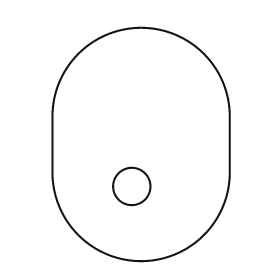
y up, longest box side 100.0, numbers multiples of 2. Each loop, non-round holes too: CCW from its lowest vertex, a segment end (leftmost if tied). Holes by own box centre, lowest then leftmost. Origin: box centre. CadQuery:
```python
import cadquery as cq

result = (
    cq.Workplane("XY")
    .moveTo(-38.0, -12.0)
    .threePointArc((0.0, -50.0), (38.0, -12.0))
    .lineTo(38.0, 12.0)
    .threePointArc((0.0, 50.0), (-38.0, 12.0))
    .close()
    .moveTo(-4.0, -18.0)
    .circle(8.0)
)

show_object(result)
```